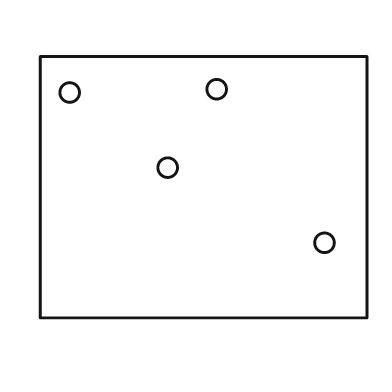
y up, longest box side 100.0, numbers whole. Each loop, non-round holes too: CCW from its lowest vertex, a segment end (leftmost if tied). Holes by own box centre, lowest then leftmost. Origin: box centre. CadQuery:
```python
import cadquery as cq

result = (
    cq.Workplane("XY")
    .moveTo(-50.0, -40.0)
    .lineTo(50.0, -40.0)
    .lineTo(50.0, 40.0)
    .lineTo(-50.0, 40.0)
    .close()
    .moveTo(37.0, -17.0)
    .circle(3.0)
    .moveTo(-11.0, 6.0)
    .circle(3.0)
    .moveTo(-41.0, 29.0)
    .circle(3.0)
    .moveTo(4.0, 30.0)
    .circle(3.0)
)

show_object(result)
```